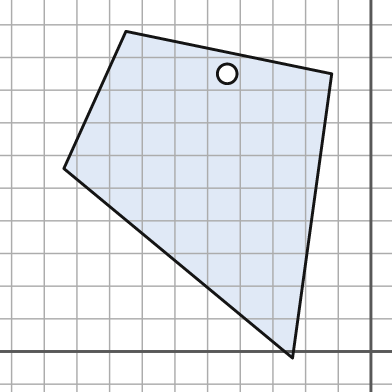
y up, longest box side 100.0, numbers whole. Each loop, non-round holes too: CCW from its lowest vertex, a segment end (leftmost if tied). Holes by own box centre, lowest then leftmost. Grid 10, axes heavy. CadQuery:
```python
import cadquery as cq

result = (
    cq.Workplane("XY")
    .moveTo(-24.0, -2.0)
    .lineTo(-12.0, 85.0)
    .lineTo(-75.0, 98.0)
    .lineTo(-94.0, 56.0)
    .close()
    .moveTo(-44.0, 85.0)
    .circle(3.0)
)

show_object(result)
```